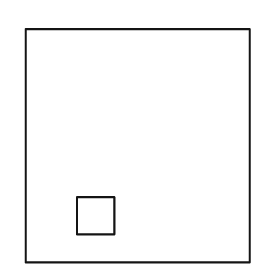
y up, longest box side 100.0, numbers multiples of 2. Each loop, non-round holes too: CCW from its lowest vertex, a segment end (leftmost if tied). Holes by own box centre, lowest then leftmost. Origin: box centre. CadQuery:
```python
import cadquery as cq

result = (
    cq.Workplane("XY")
    .moveTo(-48.0, -50.0)
    .lineTo(48.0, -50.0)
    .lineTo(48.0, 50.0)
    .lineTo(-48.0, 50.0)
    .close()
    .moveTo(-26.0, -38.0)
    .lineTo(-10.0, -38.0)
    .lineTo(-10.0, -22.0)
    .lineTo(-26.0, -22.0)
    .close()
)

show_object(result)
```